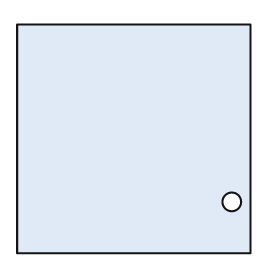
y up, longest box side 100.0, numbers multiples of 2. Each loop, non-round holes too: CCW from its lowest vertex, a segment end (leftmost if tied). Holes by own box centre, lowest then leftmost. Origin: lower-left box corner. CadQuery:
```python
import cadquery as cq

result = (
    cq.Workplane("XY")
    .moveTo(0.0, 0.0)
    .lineTo(100.0, 0.0)
    .lineTo(100.0, 98.0)
    .lineTo(0.0, 98.0)
    .close()
    .moveTo(92.0, 22.0)
    .circle(4.0)
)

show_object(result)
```